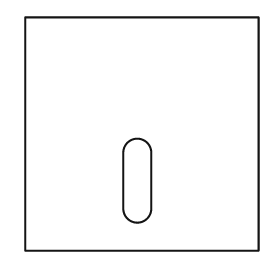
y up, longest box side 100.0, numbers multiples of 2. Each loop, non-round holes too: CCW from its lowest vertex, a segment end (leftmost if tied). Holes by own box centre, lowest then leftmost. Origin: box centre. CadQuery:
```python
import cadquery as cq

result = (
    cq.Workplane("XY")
    .moveTo(-50.0, -50.0)
    .lineTo(50.0, -50.0)
    .lineTo(50.0, 50.0)
    .lineTo(-50.0, 50.0)
    .close()
    .moveTo(-8.0, -32.0)
    .threePointArc((-2.0, -38.0), (4.0, -32.0))
    .lineTo(4.0, -8.0)
    .threePointArc((-2.0, -2.0), (-8.0, -8.0))
    .close()
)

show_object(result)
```